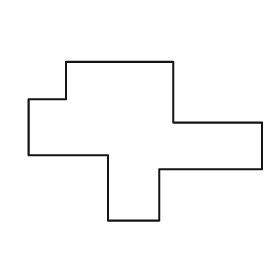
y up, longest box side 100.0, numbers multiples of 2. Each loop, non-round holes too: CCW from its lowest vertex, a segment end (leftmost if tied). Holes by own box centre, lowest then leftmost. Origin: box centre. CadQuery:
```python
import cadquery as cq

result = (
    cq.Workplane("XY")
    .moveTo(-16.0, -34.0)
    .lineTo(6.0, -34.0)
    .lineTo(6.0, -12.0)
    .lineTo(50.0, -12.0)
    .lineTo(50.0, 8.0)
    .lineTo(12.0, 8.0)
    .lineTo(12.0, 34.0)
    .lineTo(-34.0, 34.0)
    .lineTo(-34.0, 18.0)
    .lineTo(-50.0, 18.0)
    .lineTo(-50.0, -6.0)
    .lineTo(-16.0, -6.0)
    .close()
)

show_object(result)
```